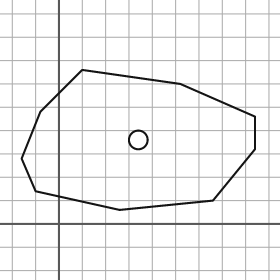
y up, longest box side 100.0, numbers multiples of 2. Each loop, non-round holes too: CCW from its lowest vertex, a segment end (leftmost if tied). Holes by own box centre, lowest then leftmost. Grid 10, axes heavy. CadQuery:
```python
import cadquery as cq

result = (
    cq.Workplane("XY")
    .moveTo(26.0, 6.0)
    .lineTo(66.0, 10.0)
    .lineTo(84.0, 32.0)
    .lineTo(84.0, 46.0)
    .lineTo(52.0, 60.0)
    .lineTo(10.0, 66.0)
    .lineTo(-8.0, 48.0)
    .lineTo(-16.0, 28.0)
    .lineTo(-10.0, 14.0)
    .close()
    .moveTo(34.0, 36.0)
    .circle(4.0)
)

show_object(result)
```